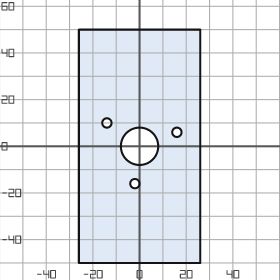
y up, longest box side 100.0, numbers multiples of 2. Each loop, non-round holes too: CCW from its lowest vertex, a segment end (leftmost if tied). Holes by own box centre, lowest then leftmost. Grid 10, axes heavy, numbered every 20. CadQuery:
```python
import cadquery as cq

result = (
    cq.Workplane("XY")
    .moveTo(-26.0, -50.0)
    .lineTo(26.0, -50.0)
    .lineTo(26.0, 50.0)
    .lineTo(-26.0, 50.0)
    .close()
    .moveTo(-2.0, -16.0)
    .circle(2.0)
    .moveTo(0.0, 0.0)
    .circle(8.0)
    .moveTo(16.0, 6.0)
    .circle(2.0)
    .moveTo(-14.0, 10.0)
    .circle(2.0)
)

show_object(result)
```